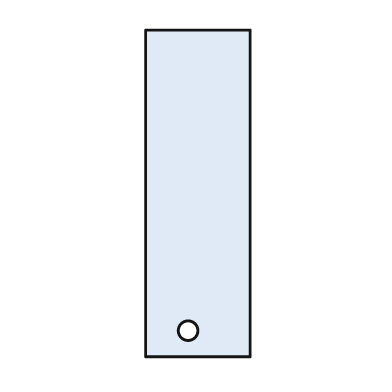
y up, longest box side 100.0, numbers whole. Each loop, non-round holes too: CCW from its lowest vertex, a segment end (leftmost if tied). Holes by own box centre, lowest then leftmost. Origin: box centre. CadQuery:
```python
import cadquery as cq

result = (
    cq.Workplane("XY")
    .moveTo(-16.0, -50.0)
    .lineTo(16.0, -50.0)
    .lineTo(16.0, 50.0)
    .lineTo(-16.0, 50.0)
    .close()
    .moveTo(-3.0, -42.0)
    .circle(3.0)
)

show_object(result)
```